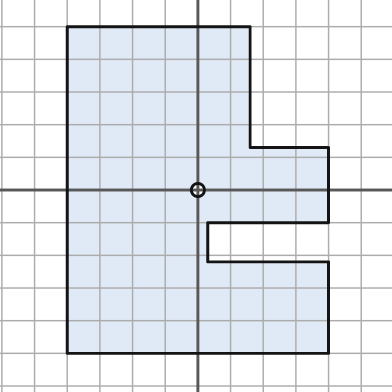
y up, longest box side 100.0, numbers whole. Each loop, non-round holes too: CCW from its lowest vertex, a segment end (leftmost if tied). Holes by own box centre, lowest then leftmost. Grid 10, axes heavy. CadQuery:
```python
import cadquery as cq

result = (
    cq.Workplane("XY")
    .moveTo(-40.0, -50.0)
    .lineTo(40.0, -50.0)
    .lineTo(40.0, -22.0)
    .lineTo(3.0, -22.0)
    .lineTo(3.0, -10.0)
    .lineTo(40.0, -10.0)
    .lineTo(40.0, 13.0)
    .lineTo(16.0, 13.0)
    .lineTo(16.0, 50.0)
    .lineTo(-40.0, 50.0)
    .close()
    .moveTo(0.0, 0.0)
    .circle(2.0)
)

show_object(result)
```